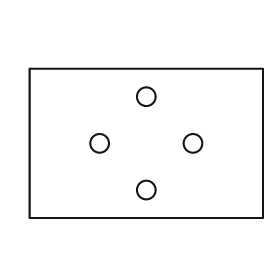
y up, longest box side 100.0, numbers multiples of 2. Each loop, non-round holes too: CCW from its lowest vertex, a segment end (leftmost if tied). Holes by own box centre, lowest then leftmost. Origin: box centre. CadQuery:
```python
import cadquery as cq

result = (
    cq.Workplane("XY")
    .moveTo(-50.0, -32.0)
    .lineTo(50.0, -32.0)
    .lineTo(50.0, 32.0)
    .lineTo(-50.0, 32.0)
    .close()
    .moveTo(0.0, -20.0)
    .circle(4.0)
    .moveTo(-20.0, 0.0)
    .circle(4.0)
    .moveTo(20.0, 0.0)
    .circle(4.0)
    .moveTo(0.0, 20.0)
    .circle(4.0)
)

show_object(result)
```